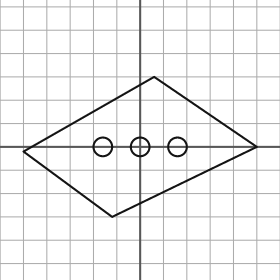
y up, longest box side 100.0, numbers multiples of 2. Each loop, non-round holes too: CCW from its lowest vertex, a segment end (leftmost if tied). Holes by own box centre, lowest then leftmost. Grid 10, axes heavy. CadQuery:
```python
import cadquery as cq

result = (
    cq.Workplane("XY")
    .moveTo(-12.0, -30.0)
    .lineTo(50.0, 0.0)
    .lineTo(6.0, 30.0)
    .lineTo(-50.0, -2.0)
    .close()
    .moveTo(-16.0, 0.0)
    .circle(4.0)
    .moveTo(0.0, 0.0)
    .circle(4.0)
    .moveTo(16.0, 0.0)
    .circle(4.0)
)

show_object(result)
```